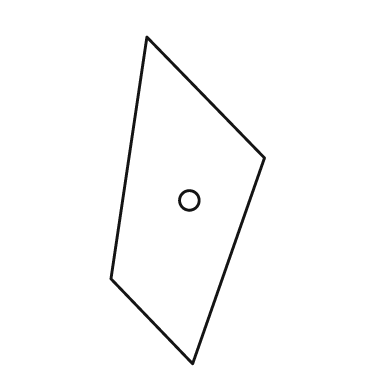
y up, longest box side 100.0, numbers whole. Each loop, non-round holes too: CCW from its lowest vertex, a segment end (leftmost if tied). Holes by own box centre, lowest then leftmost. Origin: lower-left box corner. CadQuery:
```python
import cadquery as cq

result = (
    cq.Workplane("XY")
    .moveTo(25.0, 0.0)
    .lineTo(47.0, 63.0)
    .lineTo(11.0, 100.0)
    .lineTo(0.0, 26.0)
    .close()
    .moveTo(24.0, 50.0)
    .circle(3.0)
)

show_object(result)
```